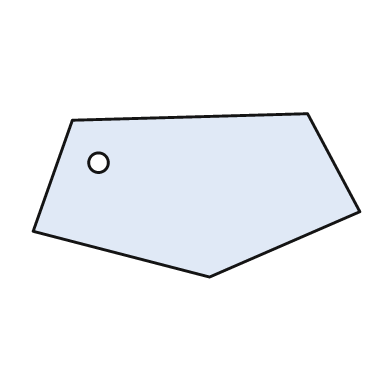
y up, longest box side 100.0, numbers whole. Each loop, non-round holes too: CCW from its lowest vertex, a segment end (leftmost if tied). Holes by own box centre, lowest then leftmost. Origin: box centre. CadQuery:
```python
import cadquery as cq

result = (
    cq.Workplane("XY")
    .moveTo(4.0, -25.0)
    .lineTo(50.0, -5.0)
    .lineTo(34.0, 25.0)
    .lineTo(-38.0, 23.0)
    .lineTo(-50.0, -11.0)
    .close()
    .moveTo(-30.0, 10.0)
    .circle(3.0)
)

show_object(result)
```